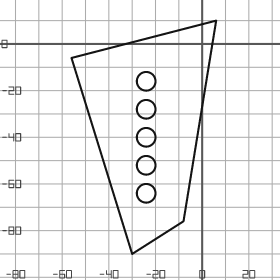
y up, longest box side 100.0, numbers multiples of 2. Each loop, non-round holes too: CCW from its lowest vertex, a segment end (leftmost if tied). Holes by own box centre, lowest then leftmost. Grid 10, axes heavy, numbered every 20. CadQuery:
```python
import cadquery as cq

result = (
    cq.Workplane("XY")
    .moveTo(-30.0, -90.0)
    .lineTo(-8.0, -76.0)
    .lineTo(6.0, 10.0)
    .lineTo(-56.0, -6.0)
    .close()
    .moveTo(-24.0, -64.0)
    .circle(4.0)
    .moveTo(-24.0, -52.0)
    .circle(4.0)
    .moveTo(-24.0, -40.0)
    .circle(4.0)
    .moveTo(-24.0, -28.0)
    .circle(4.0)
    .moveTo(-24.0, -16.0)
    .circle(4.0)
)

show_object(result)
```